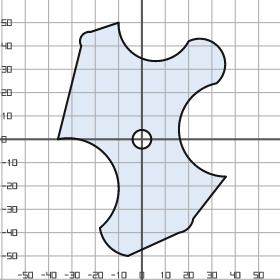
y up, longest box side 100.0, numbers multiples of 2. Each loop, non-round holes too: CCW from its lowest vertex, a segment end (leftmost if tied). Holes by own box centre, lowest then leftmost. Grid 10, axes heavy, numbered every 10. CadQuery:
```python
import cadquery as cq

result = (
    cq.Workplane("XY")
    .moveTo(-6.0, -50.0)
    .lineTo(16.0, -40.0)
    .threePointArc((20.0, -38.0), (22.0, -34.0))
    .lineTo(36.0, -16.0)
    .threePointArc((16.0, 2.0), (32.0, 24.0))
    .threePointArc((34.0, 38.0), (20.0, 42.0))
    .threePointArc((2.0, 34.0), (-10.0, 50.0))
    .lineTo(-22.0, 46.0)
    .threePointArc((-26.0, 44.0), (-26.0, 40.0))
    .lineTo(-36.0, 0.0)
    .threePointArc((-12.0, -12.0), (-18.0, -38.0))
    .threePointArc((-14.0, -46.0), (-6.0, -50.0))
    .close()
    .moveTo(0.0, 0.0)
    .circle(4.0)
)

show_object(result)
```